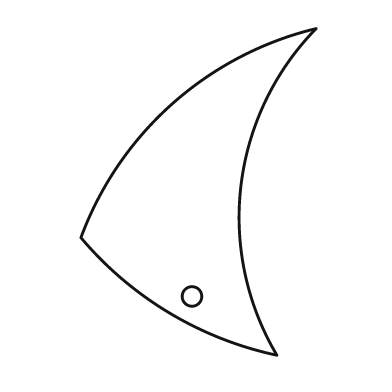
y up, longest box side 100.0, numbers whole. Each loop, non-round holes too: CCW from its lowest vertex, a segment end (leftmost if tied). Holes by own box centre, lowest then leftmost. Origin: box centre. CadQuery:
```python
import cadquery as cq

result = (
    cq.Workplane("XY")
    .moveTo(24.0, -50.0)
    .threePointArc((13.0, 2.0), (36.0, 50.0))
    .threePointArc((-8.0, 27.0), (-36.0, -14.0))
    .threePointArc((-9.0, -37.0), (24.0, -50.0))
    .close()
    .moveTo(-2.0, -32.0)
    .circle(3.0)
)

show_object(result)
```